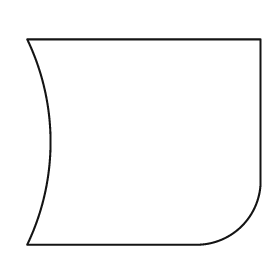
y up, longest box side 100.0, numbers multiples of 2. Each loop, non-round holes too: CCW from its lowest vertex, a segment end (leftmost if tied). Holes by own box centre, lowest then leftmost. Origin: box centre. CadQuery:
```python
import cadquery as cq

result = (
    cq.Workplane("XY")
    .moveTo(-50.0, -44.0)
    .lineTo(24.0, -44.0)
    .threePointArc((42.0, -36.0), (50.0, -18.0))
    .lineTo(50.0, 44.0)
    .lineTo(-50.0, 44.0)
    .threePointArc((-40.0, 0.0), (-50.0, -44.0))
    .close()
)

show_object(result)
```